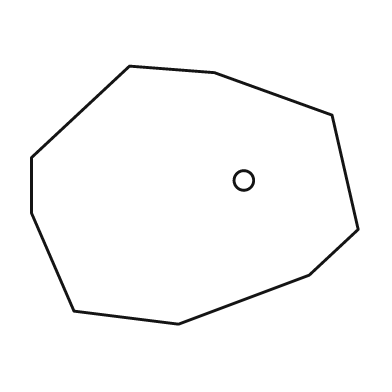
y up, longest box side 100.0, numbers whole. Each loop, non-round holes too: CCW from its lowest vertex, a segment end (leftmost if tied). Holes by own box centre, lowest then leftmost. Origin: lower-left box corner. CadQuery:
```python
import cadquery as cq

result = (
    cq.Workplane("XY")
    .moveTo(45.0, 0.0)
    .lineTo(85.0, 15.0)
    .lineTo(100.0, 29.0)
    .lineTo(92.0, 64.0)
    .lineTo(56.0, 77.0)
    .lineTo(30.0, 79.0)
    .lineTo(0.0, 51.0)
    .lineTo(0.0, 34.0)
    .lineTo(13.0, 4.0)
    .close()
    .moveTo(65.0, 44.0)
    .circle(3.0)
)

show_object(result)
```